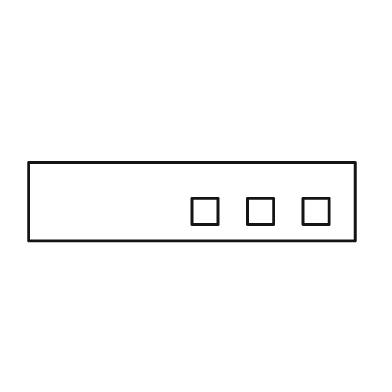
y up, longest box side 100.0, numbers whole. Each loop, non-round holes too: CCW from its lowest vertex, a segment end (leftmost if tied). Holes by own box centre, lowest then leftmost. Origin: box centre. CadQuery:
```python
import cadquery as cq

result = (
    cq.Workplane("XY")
    .moveTo(-50.0, -12.0)
    .lineTo(50.0, -12.0)
    .lineTo(50.0, 12.0)
    .lineTo(-50.0, 12.0)
    .close()
    .moveTo(0.0, -7.0)
    .lineTo(8.0, -7.0)
    .lineTo(8.0, 1.0)
    .lineTo(0.0, 1.0)
    .close()
    .moveTo(17.0, -7.0)
    .lineTo(25.0, -7.0)
    .lineTo(25.0, 1.0)
    .lineTo(17.0, 1.0)
    .close()
    .moveTo(34.0, -7.0)
    .lineTo(42.0, -7.0)
    .lineTo(42.0, 1.0)
    .lineTo(34.0, 1.0)
    .close()
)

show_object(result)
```